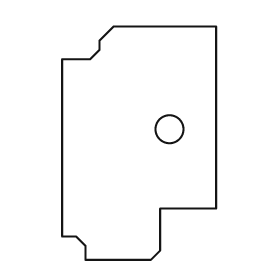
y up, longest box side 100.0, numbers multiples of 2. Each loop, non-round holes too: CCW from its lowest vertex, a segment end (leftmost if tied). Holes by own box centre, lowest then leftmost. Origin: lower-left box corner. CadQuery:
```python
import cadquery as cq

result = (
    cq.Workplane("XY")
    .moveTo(10.0, 0.0)
    .lineTo(38.0, 0.0)
    .lineTo(42.0, 4.0)
    .lineTo(42.0, 22.0)
    .lineTo(66.0, 22.0)
    .lineTo(66.0, 100.0)
    .lineTo(22.0, 100.0)
    .lineTo(16.0, 94.0)
    .lineTo(16.0, 90.0)
    .lineTo(12.0, 86.0)
    .lineTo(0.0, 86.0)
    .lineTo(0.0, 10.0)
    .lineTo(6.0, 10.0)
    .lineTo(10.0, 6.0)
    .close()
    .moveTo(46.0, 56.0)
    .circle(6.0)
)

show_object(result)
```